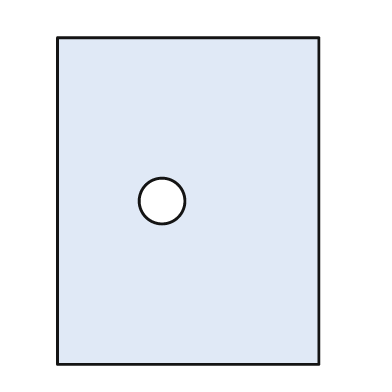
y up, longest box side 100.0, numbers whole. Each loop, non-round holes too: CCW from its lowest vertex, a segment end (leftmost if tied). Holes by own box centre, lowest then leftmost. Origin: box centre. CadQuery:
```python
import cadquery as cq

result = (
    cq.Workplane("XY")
    .moveTo(-40.0, -50.0)
    .lineTo(40.0, -50.0)
    .lineTo(40.0, 50.0)
    .lineTo(-40.0, 50.0)
    .close()
    .moveTo(-8.0, 0.0)
    .circle(7.0)
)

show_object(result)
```